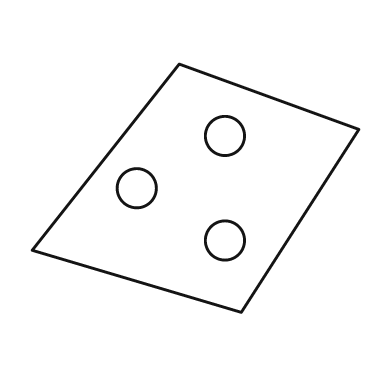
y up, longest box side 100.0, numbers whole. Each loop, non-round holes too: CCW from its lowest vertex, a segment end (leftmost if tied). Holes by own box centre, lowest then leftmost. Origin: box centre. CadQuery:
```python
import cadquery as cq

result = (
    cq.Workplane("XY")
    .moveTo(14.0, -38.0)
    .lineTo(50.0, 18.0)
    .lineTo(-5.0, 38.0)
    .lineTo(-50.0, -19.0)
    .close()
    .moveTo(9.0, -16.0)
    .circle(6.0)
    .moveTo(-18.0, 0.0)
    .circle(6.0)
    .moveTo(9.0, 16.0)
    .circle(6.0)
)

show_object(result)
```